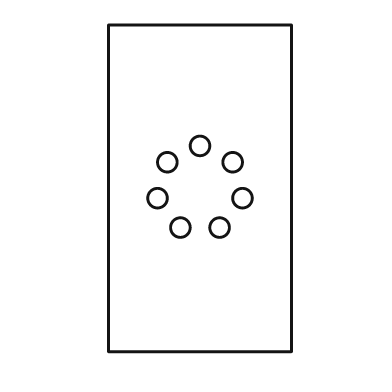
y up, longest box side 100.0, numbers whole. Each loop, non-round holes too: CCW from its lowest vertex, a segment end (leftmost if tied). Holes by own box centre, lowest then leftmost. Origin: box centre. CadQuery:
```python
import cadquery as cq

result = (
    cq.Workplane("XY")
    .moveTo(-28.0, -50.0)
    .lineTo(28.0, -50.0)
    .lineTo(28.0, 50.0)
    .lineTo(-28.0, 50.0)
    .close()
    .moveTo(-6.0, -12.0)
    .circle(3.0)
    .moveTo(6.0, -12.0)
    .circle(3.0)
    .moveTo(-13.0, -3.0)
    .circle(3.0)
    .moveTo(13.0, -3.0)
    .circle(3.0)
    .moveTo(-10.0, 8.0)
    .circle(3.0)
    .moveTo(10.0, 8.0)
    .circle(3.0)
    .moveTo(0.0, 13.0)
    .circle(3.0)
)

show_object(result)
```